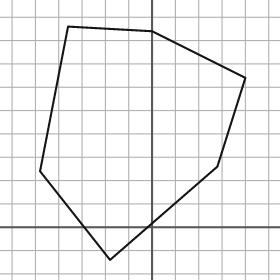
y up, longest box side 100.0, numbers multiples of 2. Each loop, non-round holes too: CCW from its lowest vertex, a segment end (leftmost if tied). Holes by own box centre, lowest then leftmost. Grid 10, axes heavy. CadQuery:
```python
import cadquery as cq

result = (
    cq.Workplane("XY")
    .moveTo(-18.0, -14.0)
    .lineTo(28.0, 26.0)
    .lineTo(40.0, 64.0)
    .lineTo(0.0, 84.0)
    .lineTo(-36.0, 86.0)
    .lineTo(-48.0, 24.0)
    .close()
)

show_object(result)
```